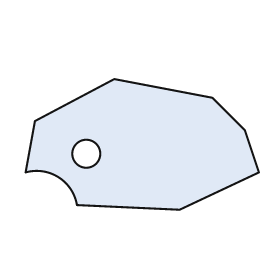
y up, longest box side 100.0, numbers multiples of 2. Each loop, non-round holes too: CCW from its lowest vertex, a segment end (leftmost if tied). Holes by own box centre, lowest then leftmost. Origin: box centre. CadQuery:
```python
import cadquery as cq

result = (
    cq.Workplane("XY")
    .moveTo(16.0, -28.0)
    .lineTo(50.0, -12.0)
    .lineTo(44.0, 6.0)
    .lineTo(30.0, 20.0)
    .lineTo(-12.0, 28.0)
    .lineTo(-46.0, 10.0)
    .lineTo(-50.0, -12.0)
    .threePointArc((-36.0, -14.0), (-28.0, -26.0))
    .close()
    .moveTo(-24.0, -4.0)
    .circle(6.0)
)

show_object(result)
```